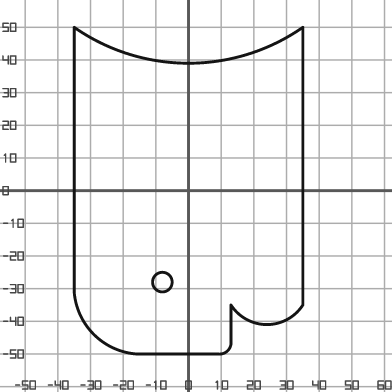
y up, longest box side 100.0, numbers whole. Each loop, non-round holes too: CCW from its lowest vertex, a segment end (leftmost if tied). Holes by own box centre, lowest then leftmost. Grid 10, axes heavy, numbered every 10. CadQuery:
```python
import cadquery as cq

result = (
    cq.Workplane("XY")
    .moveTo(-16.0, -50.0)
    .lineTo(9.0, -50.0)
    .threePointArc((12.0, -49.0), (13.0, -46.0))
    .lineTo(13.0, -35.0)
    .threePointArc((24.0, -41.0), (35.0, -35.0))
    .lineTo(35.0, 50.0)
    .threePointArc((0.0, 39.0), (-35.0, 50.0))
    .lineTo(-35.0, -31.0)
    .threePointArc((-29.0, -44.0), (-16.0, -50.0))
    .close()
    .moveTo(-8.0, -28.0)
    .circle(3.0)
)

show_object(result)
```